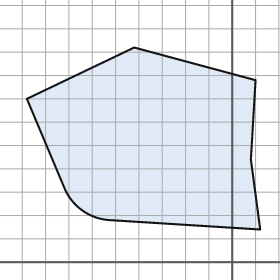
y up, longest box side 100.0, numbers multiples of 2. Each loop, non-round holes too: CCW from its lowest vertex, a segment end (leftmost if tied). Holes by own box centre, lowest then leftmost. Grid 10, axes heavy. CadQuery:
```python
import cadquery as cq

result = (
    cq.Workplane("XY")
    .moveTo(12.0, 14.0)
    .lineTo(8.0, 44.0)
    .lineTo(10.0, 78.0)
    .lineTo(-42.0, 92.0)
    .lineTo(-88.0, 70.0)
    .lineTo(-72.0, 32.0)
    .threePointArc((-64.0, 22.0), (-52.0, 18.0))
    .close()
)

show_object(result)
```